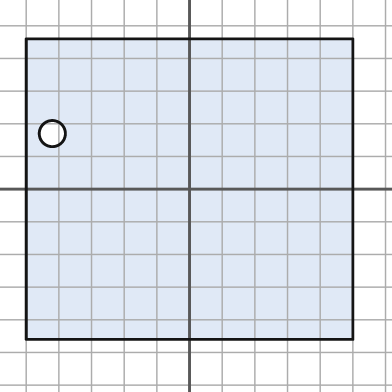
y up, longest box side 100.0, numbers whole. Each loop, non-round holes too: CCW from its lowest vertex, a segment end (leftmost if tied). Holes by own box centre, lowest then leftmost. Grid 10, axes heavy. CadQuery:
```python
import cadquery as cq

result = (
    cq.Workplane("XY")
    .moveTo(-50.0, -46.0)
    .lineTo(50.0, -46.0)
    .lineTo(50.0, 46.0)
    .lineTo(-50.0, 46.0)
    .close()
    .moveTo(-42.0, 17.0)
    .circle(4.0)
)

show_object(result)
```